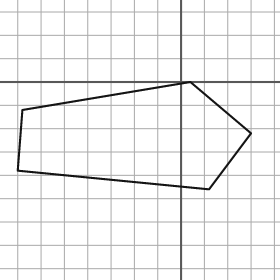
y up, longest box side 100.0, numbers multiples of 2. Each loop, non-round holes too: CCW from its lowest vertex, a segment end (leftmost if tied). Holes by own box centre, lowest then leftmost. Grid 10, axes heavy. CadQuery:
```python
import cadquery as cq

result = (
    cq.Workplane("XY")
    .moveTo(12.0, -46.0)
    .lineTo(30.0, -22.0)
    .lineTo(4.0, 0.0)
    .lineTo(-68.0, -12.0)
    .lineTo(-70.0, -38.0)
    .close()
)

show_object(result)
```